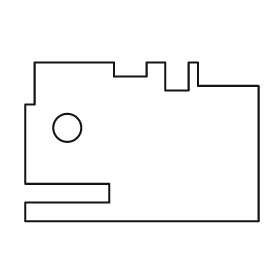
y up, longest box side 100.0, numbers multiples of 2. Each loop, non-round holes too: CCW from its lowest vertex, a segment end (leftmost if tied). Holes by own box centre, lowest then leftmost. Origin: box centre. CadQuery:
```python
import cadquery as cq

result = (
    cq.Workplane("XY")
    .moveTo(-50.0, -34.0)
    .lineTo(50.0, -34.0)
    .lineTo(50.0, 24.0)
    .lineTo(24.0, 24.0)
    .lineTo(24.0, 34.0)
    .lineTo(20.0, 34.0)
    .lineTo(20.0, 22.0)
    .lineTo(10.0, 22.0)
    .lineTo(10.0, 34.0)
    .lineTo(2.0, 34.0)
    .lineTo(2.0, 28.0)
    .lineTo(-12.0, 28.0)
    .lineTo(-12.0, 34.0)
    .lineTo(-46.0, 34.0)
    .lineTo(-46.0, 16.0)
    .lineTo(-50.0, 16.0)
    .lineTo(-50.0, -18.0)
    .lineTo(-14.0, -18.0)
    .lineTo(-14.0, -26.0)
    .lineTo(-50.0, -26.0)
    .close()
    .moveTo(-32.0, 6.0)
    .circle(6.0)
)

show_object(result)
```